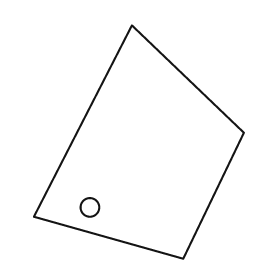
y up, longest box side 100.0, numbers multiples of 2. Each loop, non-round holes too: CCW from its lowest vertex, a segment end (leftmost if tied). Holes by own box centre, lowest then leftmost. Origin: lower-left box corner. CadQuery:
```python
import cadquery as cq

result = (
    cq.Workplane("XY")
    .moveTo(64.0, 0.0)
    .lineTo(90.0, 54.0)
    .lineTo(42.0, 100.0)
    .lineTo(0.0, 18.0)
    .close()
    .moveTo(24.0, 22.0)
    .circle(4.0)
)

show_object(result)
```